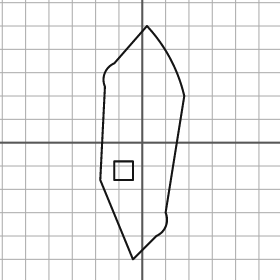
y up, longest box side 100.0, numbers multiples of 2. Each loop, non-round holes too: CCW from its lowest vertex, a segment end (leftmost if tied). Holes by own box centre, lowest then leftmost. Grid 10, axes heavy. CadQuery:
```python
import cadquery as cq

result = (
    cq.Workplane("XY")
    .moveTo(-4.0, -50.0)
    .lineTo(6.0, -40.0)
    .threePointArc((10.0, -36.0), (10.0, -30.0))
    .lineTo(18.0, 20.0)
    .threePointArc((12.0, 36.0), (2.0, 50.0))
    .lineTo(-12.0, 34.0)
    .threePointArc((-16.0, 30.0), (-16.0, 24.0))
    .lineTo(-18.0, -16.0)
    .close()
    .moveTo(-12.0, -16.0)
    .lineTo(-4.0, -16.0)
    .lineTo(-4.0, -8.0)
    .lineTo(-12.0, -8.0)
    .close()
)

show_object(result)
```